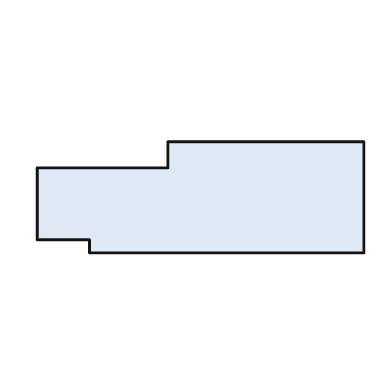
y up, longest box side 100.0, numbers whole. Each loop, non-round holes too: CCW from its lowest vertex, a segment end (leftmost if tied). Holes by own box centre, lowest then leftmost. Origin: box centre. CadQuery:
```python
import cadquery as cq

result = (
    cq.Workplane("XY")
    .moveTo(-34.0, -17.0)
    .lineTo(50.0, -17.0)
    .lineTo(50.0, 17.0)
    .lineTo(-10.0, 17.0)
    .lineTo(-10.0, 9.0)
    .lineTo(-50.0, 9.0)
    .lineTo(-50.0, -13.0)
    .lineTo(-34.0, -13.0)
    .close()
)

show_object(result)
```